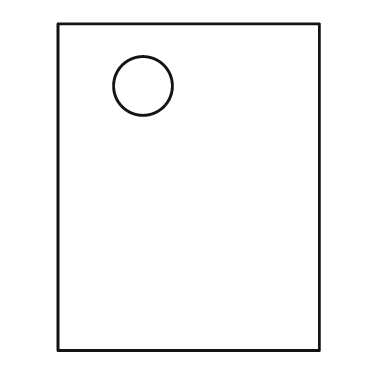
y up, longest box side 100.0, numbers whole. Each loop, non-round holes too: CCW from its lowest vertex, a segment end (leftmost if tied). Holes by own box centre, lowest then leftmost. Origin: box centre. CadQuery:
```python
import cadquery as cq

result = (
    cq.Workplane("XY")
    .moveTo(-40.0, -50.0)
    .lineTo(40.0, -50.0)
    .lineTo(40.0, 50.0)
    .lineTo(-40.0, 50.0)
    .close()
    .moveTo(-14.0, 31.0)
    .circle(9.0)
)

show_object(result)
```